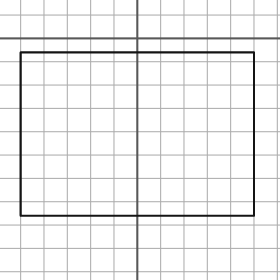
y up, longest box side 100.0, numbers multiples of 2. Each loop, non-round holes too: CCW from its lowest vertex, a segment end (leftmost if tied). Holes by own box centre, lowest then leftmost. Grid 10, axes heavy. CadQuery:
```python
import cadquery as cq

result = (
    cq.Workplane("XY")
    .moveTo(-50.0, -76.0)
    .lineTo(50.0, -76.0)
    .lineTo(50.0, -6.0)
    .lineTo(-50.0, -6.0)
    .close()
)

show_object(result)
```